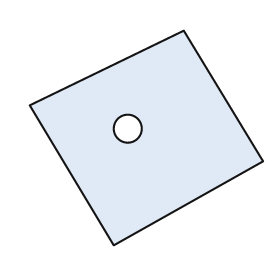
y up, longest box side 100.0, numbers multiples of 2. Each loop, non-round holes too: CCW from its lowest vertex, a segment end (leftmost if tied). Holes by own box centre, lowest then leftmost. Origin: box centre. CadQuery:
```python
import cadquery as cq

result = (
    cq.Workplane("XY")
    .moveTo(-14.0, -46.0)
    .lineTo(50.0, -10.0)
    .lineTo(16.0, 46.0)
    .lineTo(-50.0, 14.0)
    .close()
    .moveTo(-8.0, 4.0)
    .circle(6.0)
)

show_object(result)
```